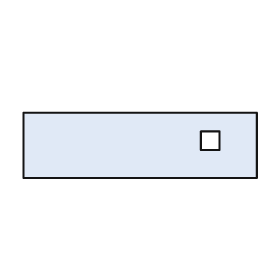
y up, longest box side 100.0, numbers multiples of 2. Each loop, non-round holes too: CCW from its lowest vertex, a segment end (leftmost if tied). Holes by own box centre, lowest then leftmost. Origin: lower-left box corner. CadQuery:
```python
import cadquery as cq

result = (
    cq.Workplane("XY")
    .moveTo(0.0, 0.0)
    .lineTo(100.0, 0.0)
    .lineTo(100.0, 28.0)
    .lineTo(0.0, 28.0)
    .close()
    .moveTo(76.0, 12.0)
    .lineTo(84.0, 12.0)
    .lineTo(84.0, 20.0)
    .lineTo(76.0, 20.0)
    .close()
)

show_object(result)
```